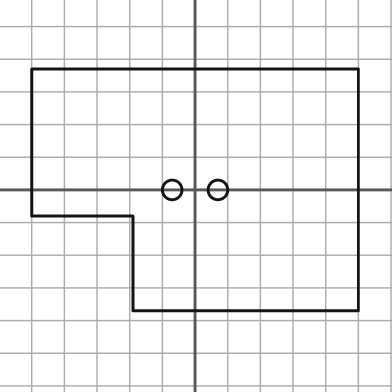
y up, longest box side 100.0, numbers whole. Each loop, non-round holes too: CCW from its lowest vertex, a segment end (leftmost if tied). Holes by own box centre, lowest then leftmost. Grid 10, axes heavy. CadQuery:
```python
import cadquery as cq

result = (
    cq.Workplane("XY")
    .moveTo(-19.0, -37.0)
    .lineTo(50.0, -37.0)
    .lineTo(50.0, 37.0)
    .lineTo(-50.0, 37.0)
    .lineTo(-50.0, -8.0)
    .lineTo(-19.0, -8.0)
    .close()
    .moveTo(-7.0, 0.0)
    .circle(3.0)
    .moveTo(7.0, 0.0)
    .circle(3.0)
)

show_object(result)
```